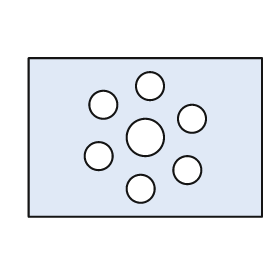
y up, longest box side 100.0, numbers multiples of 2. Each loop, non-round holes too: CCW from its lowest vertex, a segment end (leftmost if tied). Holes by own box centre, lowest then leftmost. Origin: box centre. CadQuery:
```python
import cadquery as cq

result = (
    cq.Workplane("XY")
    .moveTo(-50.0, -34.0)
    .lineTo(50.0, -34.0)
    .lineTo(50.0, 34.0)
    .lineTo(-50.0, 34.0)
    .close()
    .moveTo(-2.0, -22.0)
    .circle(6.0)
    .moveTo(18.0, -14.0)
    .circle(6.0)
    .moveTo(-20.0, -8.0)
    .circle(6.0)
    .moveTo(0.0, 0.0)
    .circle(8.0)
    .moveTo(20.0, 8.0)
    .circle(6.0)
    .moveTo(-18.0, 14.0)
    .circle(6.0)
    .moveTo(2.0, 22.0)
    .circle(6.0)
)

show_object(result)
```